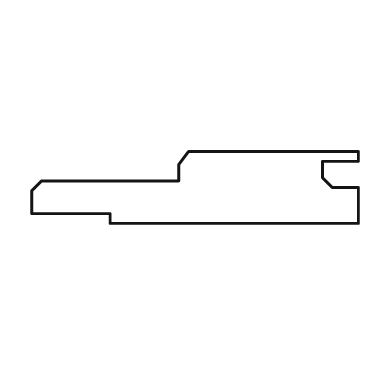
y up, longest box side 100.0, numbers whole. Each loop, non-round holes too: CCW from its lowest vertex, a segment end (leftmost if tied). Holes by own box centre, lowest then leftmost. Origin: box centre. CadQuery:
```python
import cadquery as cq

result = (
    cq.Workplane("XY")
    .moveTo(-26.0, -11.0)
    .lineTo(50.0, -11.0)
    .lineTo(50.0, 0.0)
    .lineTo(42.0, 0.0)
    .lineTo(39.0, 3.0)
    .lineTo(39.0, 8.0)
    .lineTo(50.0, 8.0)
    .lineTo(50.0, 11.0)
    .lineTo(-2.0, 11.0)
    .lineTo(-5.0, 7.0)
    .lineTo(-5.0, 2.0)
    .lineTo(-47.0, 2.0)
    .lineTo(-50.0, -1.0)
    .lineTo(-50.0, -8.0)
    .lineTo(-26.0, -8.0)
    .close()
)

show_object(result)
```